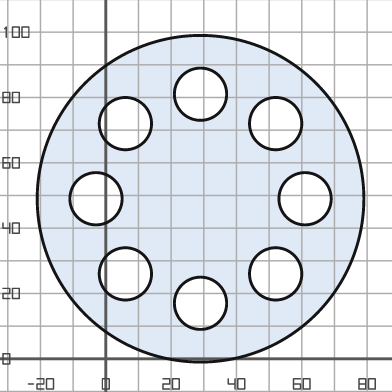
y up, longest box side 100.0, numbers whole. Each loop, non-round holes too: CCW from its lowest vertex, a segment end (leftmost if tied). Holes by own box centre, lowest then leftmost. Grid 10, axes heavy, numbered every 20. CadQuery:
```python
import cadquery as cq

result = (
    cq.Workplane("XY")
    .moveTo(29.0, 49.0)
    .circle(50.0)
    .moveTo(29.0, 17.0)
    .circle(8.0)
    .moveTo(6.0, 26.0)
    .circle(8.0)
    .moveTo(52.0, 26.0)
    .circle(8.0)
    .moveTo(-3.0, 49.0)
    .circle(8.0)
    .moveTo(61.0, 49.0)
    .circle(8.0)
    .moveTo(6.0, 72.0)
    .circle(8.0)
    .moveTo(52.0, 72.0)
    .circle(8.0)
    .moveTo(29.0, 81.0)
    .circle(8.0)
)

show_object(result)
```